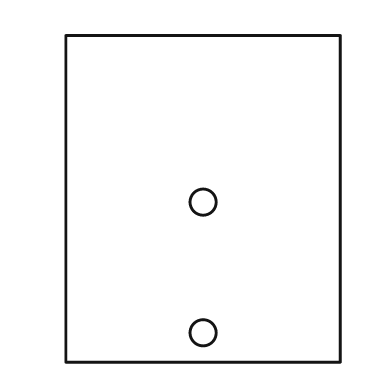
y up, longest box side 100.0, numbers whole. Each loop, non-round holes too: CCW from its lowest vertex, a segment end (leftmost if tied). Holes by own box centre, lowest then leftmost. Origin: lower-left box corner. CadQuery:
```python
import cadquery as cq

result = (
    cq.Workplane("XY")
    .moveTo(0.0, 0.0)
    .lineTo(84.0, 0.0)
    .lineTo(84.0, 100.0)
    .lineTo(0.0, 100.0)
    .close()
    .moveTo(42.0, 9.0)
    .circle(4.0)
    .moveTo(42.0, 49.0)
    .circle(4.0)
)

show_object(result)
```